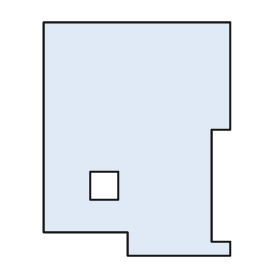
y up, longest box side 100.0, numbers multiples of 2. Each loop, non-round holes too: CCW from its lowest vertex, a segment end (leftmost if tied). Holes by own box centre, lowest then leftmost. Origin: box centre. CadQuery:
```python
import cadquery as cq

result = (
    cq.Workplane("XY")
    .moveTo(-4.0, -50.0)
    .lineTo(40.0, -50.0)
    .lineTo(40.0, -44.0)
    .lineTo(32.0, -44.0)
    .lineTo(32.0, 4.0)
    .lineTo(40.0, 4.0)
    .lineTo(40.0, 50.0)
    .lineTo(-40.0, 50.0)
    .lineTo(-40.0, -40.0)
    .lineTo(-4.0, -40.0)
    .close()
    .moveTo(-20.0, -26.0)
    .lineTo(-8.0, -26.0)
    .lineTo(-8.0, -14.0)
    .lineTo(-20.0, -14.0)
    .close()
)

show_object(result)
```